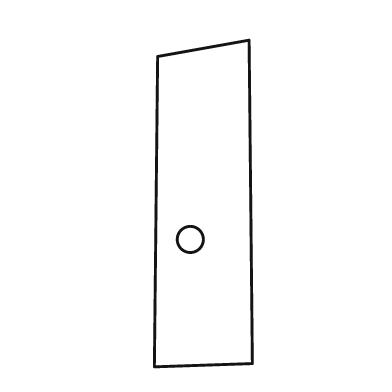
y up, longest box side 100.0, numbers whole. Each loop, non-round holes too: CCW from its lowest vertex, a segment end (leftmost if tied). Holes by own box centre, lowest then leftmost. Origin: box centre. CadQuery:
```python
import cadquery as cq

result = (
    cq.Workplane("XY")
    .moveTo(-15.0, -50.0)
    .lineTo(15.0, -49.0)
    .lineTo(14.0, 50.0)
    .lineTo(-14.0, 45.0)
    .close()
    .moveTo(-4.0, -11.0)
    .circle(4.0)
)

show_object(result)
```